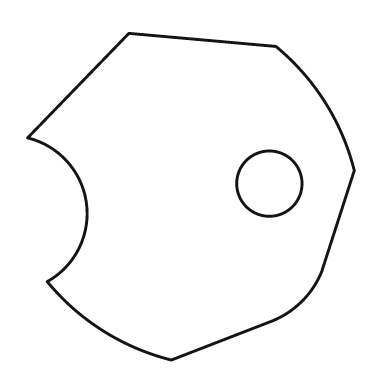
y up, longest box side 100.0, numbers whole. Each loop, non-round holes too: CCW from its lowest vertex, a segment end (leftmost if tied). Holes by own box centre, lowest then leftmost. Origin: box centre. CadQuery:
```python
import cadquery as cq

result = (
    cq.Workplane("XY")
    .moveTo(-6.0, -50.0)
    .lineTo(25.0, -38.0)
    .threePointArc((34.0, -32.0), (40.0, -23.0))
    .lineTo(50.0, 8.0)
    .threePointArc((41.0, 29.0), (26.0, 46.0))
    .lineTo(-19.0, 50.0)
    .lineTo(-50.0, 18.0)
    .threePointArc((-32.0, -2.0), (-44.0, -26.0))
    .threePointArc((-27.0, -41.0), (-6.0, -50.0))
    .close()
    .moveTo(24.0, 4.0)
    .circle(10.0)
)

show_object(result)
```